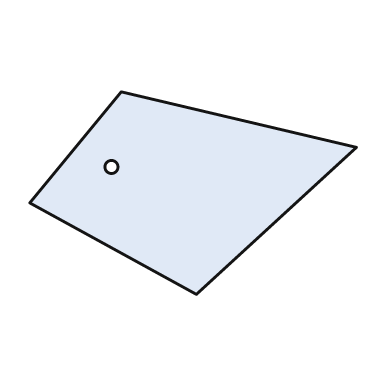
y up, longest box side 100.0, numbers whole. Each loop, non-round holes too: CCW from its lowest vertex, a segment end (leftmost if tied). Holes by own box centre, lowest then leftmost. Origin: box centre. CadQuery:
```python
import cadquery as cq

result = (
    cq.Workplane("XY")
    .moveTo(1.0, -31.0)
    .lineTo(50.0, 14.0)
    .lineTo(-22.0, 31.0)
    .lineTo(-50.0, -3.0)
    .close()
    .moveTo(-25.0, 8.0)
    .circle(2.0)
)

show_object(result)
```